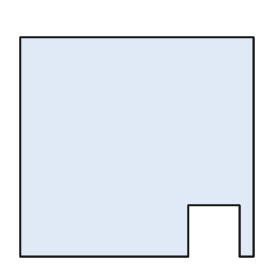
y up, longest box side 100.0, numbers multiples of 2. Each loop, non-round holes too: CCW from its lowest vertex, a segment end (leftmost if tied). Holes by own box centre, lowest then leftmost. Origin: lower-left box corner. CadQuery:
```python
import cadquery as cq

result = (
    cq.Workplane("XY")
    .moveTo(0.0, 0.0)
    .lineTo(72.0, 0.0)
    .lineTo(72.0, 22.0)
    .lineTo(94.0, 22.0)
    .lineTo(94.0, 0.0)
    .lineTo(100.0, 0.0)
    .lineTo(100.0, 94.0)
    .lineTo(0.0, 94.0)
    .close()
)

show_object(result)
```